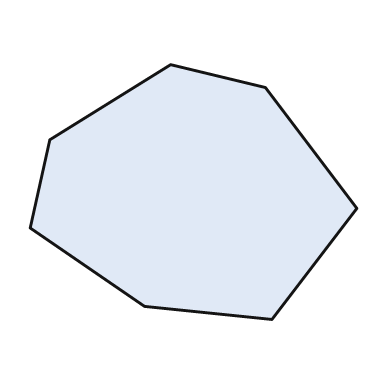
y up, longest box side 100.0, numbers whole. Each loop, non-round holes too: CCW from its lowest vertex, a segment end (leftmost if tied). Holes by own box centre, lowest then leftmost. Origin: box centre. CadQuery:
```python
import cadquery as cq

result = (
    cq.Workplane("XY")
    .moveTo(24.0, -39.0)
    .lineTo(50.0, -5.0)
    .lineTo(22.0, 32.0)
    .lineTo(-7.0, 39.0)
    .lineTo(-44.0, 16.0)
    .lineTo(-50.0, -11.0)
    .lineTo(-15.0, -35.0)
    .close()
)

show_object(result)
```